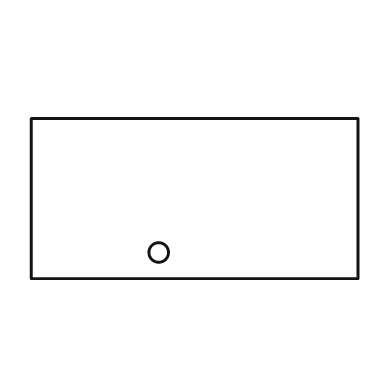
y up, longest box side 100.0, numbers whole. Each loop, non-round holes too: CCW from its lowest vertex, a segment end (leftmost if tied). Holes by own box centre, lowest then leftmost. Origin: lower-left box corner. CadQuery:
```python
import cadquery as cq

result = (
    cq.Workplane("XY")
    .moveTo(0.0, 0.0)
    .lineTo(100.0, 0.0)
    .lineTo(100.0, 49.0)
    .lineTo(0.0, 49.0)
    .close()
    .moveTo(39.0, 8.0)
    .circle(3.0)
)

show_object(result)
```